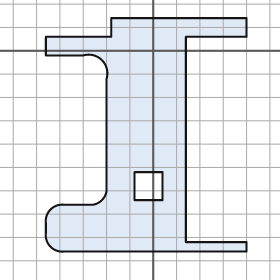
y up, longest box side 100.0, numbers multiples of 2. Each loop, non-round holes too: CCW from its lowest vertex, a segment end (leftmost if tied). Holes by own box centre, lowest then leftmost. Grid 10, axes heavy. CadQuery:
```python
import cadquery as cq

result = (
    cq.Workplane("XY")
    .moveTo(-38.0, -86.0)
    .lineTo(40.0, -86.0)
    .lineTo(40.0, -82.0)
    .lineTo(14.0, -82.0)
    .lineTo(14.0, 6.0)
    .lineTo(40.0, 6.0)
    .lineTo(40.0, 14.0)
    .lineTo(-18.0, 14.0)
    .lineTo(-18.0, 6.0)
    .lineTo(-46.0, 6.0)
    .lineTo(-46.0, -2.0)
    .lineTo(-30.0, -2.0)
    .threePointArc((-22.0, -4.0), (-20.0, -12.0))
    .lineTo(-20.0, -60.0)
    .threePointArc((-22.0, -64.0), (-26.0, -66.0))
    .lineTo(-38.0, -66.0)
    .threePointArc((-44.0, -68.0), (-46.0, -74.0))
    .lineTo(-46.0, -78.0)
    .threePointArc((-44.0, -84.0), (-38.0, -86.0))
    .close()
    .moveTo(-8.0, -64.0)
    .lineTo(4.0, -64.0)
    .lineTo(4.0, -52.0)
    .lineTo(-8.0, -52.0)
    .close()
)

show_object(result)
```